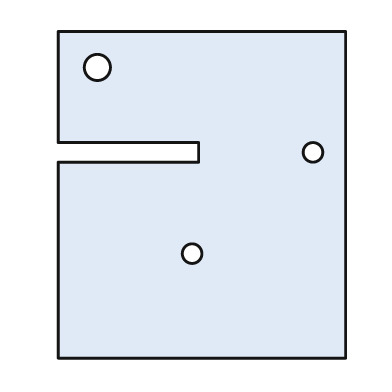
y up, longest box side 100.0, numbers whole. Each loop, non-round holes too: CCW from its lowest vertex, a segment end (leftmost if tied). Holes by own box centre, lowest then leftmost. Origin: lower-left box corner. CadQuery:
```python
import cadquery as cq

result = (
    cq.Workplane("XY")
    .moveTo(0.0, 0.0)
    .lineTo(88.0, 0.0)
    .lineTo(88.0, 100.0)
    .lineTo(0.0, 100.0)
    .lineTo(0.0, 66.0)
    .lineTo(43.0, 66.0)
    .lineTo(43.0, 60.0)
    .lineTo(0.0, 60.0)
    .close()
    .moveTo(41.0, 32.0)
    .circle(3.0)
    .moveTo(78.0, 63.0)
    .circle(3.0)
    .moveTo(12.0, 89.0)
    .circle(4.0)
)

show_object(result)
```